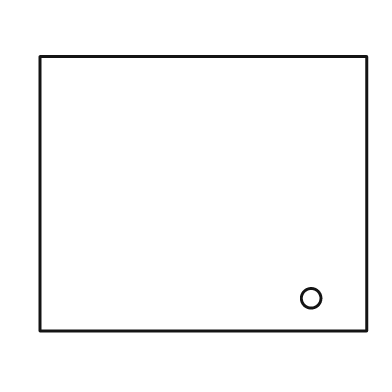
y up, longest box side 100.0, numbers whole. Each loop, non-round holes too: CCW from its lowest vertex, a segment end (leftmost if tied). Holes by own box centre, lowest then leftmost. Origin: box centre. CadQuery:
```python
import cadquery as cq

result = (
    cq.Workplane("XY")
    .moveTo(-50.0, -42.0)
    .lineTo(50.0, -42.0)
    .lineTo(50.0, 42.0)
    .lineTo(-50.0, 42.0)
    .close()
    .moveTo(33.0, -32.0)
    .circle(3.0)
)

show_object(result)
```